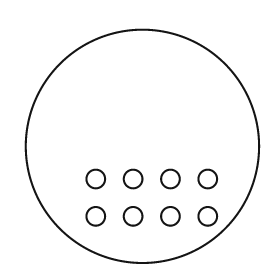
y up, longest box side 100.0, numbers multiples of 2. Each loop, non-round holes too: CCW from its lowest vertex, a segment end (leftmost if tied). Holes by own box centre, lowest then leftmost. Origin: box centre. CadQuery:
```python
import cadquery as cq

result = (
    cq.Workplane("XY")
    .moveTo(0.0, 0.0)
    .circle(50.0)
    .moveTo(-20.0, -30.0)
    .circle(4.0)
    .moveTo(-4.0, -30.0)
    .circle(4.0)
    .moveTo(12.0, -30.0)
    .circle(4.0)
    .moveTo(28.0, -30.0)
    .circle(4.0)
    .moveTo(-20.0, -14.0)
    .circle(4.0)
    .moveTo(-4.0, -14.0)
    .circle(4.0)
    .moveTo(12.0, -14.0)
    .circle(4.0)
    .moveTo(28.0, -14.0)
    .circle(4.0)
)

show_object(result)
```